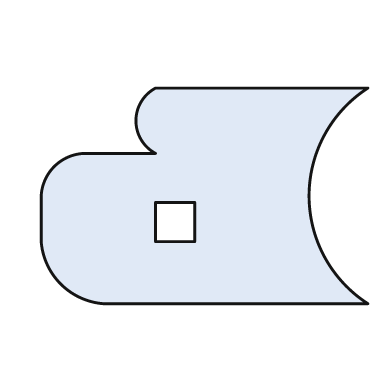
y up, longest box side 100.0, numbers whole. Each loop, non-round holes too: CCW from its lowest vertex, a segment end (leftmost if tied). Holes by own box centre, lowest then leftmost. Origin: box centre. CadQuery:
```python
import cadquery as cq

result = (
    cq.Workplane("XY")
    .moveTo(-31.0, -33.0)
    .lineTo(50.0, -33.0)
    .threePointArc((32.0, 0.0), (50.0, 33.0))
    .lineTo(-15.0, 33.0)
    .threePointArc((-21.0, 23.0), (-15.0, 13.0))
    .lineTo(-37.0, 13.0)
    .threePointArc((-46.0, 9.0), (-50.0, 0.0))
    .lineTo(-50.0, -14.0)
    .threePointArc((-44.0, -27.0), (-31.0, -33.0))
    .close()
    .moveTo(-15.0, -14.0)
    .lineTo(-3.0, -14.0)
    .lineTo(-3.0, -2.0)
    .lineTo(-15.0, -2.0)
    .close()
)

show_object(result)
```